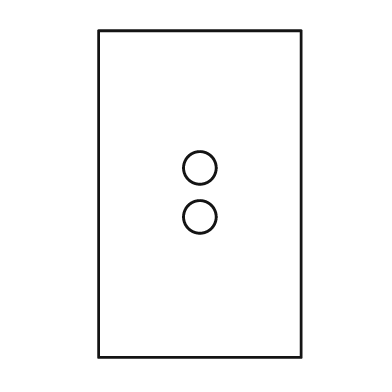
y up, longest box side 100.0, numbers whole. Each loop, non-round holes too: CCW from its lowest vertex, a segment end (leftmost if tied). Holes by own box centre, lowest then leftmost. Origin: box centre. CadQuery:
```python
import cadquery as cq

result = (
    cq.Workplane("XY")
    .moveTo(-31.0, -50.0)
    .lineTo(31.0, -50.0)
    .lineTo(31.0, 50.0)
    .lineTo(-31.0, 50.0)
    .close()
    .moveTo(0.0, -7.0)
    .circle(5.0)
    .moveTo(0.0, 8.0)
    .circle(5.0)
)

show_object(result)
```